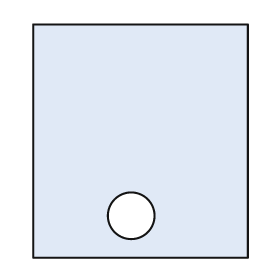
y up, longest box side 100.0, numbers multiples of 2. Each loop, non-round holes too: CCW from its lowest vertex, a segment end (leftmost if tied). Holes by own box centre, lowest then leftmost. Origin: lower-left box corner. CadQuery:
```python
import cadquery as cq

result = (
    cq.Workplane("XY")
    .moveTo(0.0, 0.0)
    .lineTo(92.0, 0.0)
    .lineTo(92.0, 100.0)
    .lineTo(0.0, 100.0)
    .close()
    .moveTo(42.0, 18.0)
    .circle(10.0)
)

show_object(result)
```